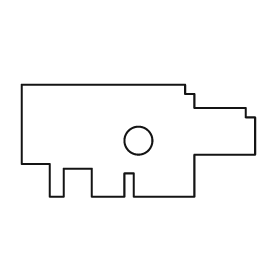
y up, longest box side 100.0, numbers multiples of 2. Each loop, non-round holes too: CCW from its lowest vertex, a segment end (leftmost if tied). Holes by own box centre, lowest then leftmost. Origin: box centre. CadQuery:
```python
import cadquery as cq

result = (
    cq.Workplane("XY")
    .moveTo(-38.0, -24.0)
    .lineTo(-32.0, -24.0)
    .lineTo(-32.0, -12.0)
    .lineTo(-20.0, -12.0)
    .lineTo(-20.0, -24.0)
    .lineTo(-6.0, -24.0)
    .lineTo(-6.0, -14.0)
    .lineTo(-2.0, -14.0)
    .lineTo(-2.0, -24.0)
    .lineTo(24.0, -24.0)
    .lineTo(24.0, -6.0)
    .lineTo(50.0, -6.0)
    .lineTo(50.0, 10.0)
    .lineTo(46.0, 10.0)
    .lineTo(46.0, 14.0)
    .lineTo(24.0, 14.0)
    .lineTo(24.0, 20.0)
    .lineTo(20.0, 20.0)
    .lineTo(20.0, 24.0)
    .lineTo(-50.0, 24.0)
    .lineTo(-50.0, -10.0)
    .lineTo(-38.0, -10.0)
    .close()
    .moveTo(0.0, 0.0)
    .circle(6.0)
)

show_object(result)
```